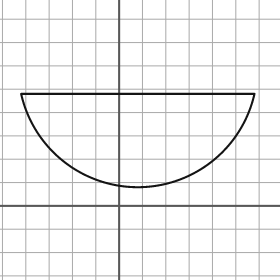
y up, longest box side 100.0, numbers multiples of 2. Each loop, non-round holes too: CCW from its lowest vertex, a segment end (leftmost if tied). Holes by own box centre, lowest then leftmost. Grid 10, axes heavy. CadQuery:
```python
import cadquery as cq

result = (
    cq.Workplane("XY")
    .moveTo(-42.0, 48.0)
    .threePointArc((8.0, 8.0), (58.0, 48.0))
    .close()
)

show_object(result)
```